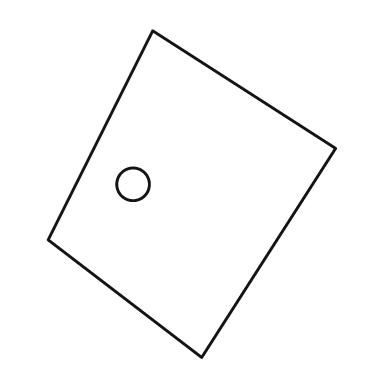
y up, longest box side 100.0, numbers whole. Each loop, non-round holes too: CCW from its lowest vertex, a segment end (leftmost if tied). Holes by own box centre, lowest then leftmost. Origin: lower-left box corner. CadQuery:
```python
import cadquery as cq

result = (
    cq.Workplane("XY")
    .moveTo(47.0, 0.0)
    .lineTo(88.0, 64.0)
    .lineTo(32.0, 100.0)
    .lineTo(0.0, 36.0)
    .close()
    .moveTo(26.0, 53.0)
    .circle(5.0)
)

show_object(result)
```